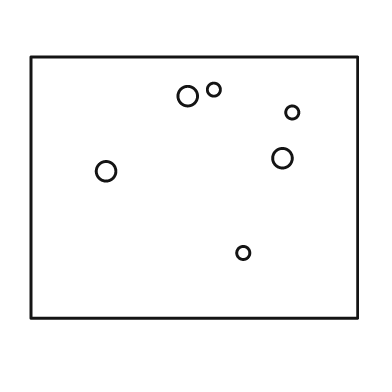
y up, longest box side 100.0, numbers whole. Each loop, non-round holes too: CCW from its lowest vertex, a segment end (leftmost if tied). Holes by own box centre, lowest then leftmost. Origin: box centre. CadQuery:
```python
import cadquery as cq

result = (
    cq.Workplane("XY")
    .moveTo(-50.0, -40.0)
    .lineTo(50.0, -40.0)
    .lineTo(50.0, 40.0)
    .lineTo(-50.0, 40.0)
    .close()
    .moveTo(15.0, -20.0)
    .circle(2.0)
    .moveTo(-27.0, 5.0)
    .circle(3.0)
    .moveTo(27.0, 9.0)
    .circle(3.0)
    .moveTo(30.0, 23.0)
    .circle(2.0)
    .moveTo(-2.0, 28.0)
    .circle(3.0)
    .moveTo(6.0, 30.0)
    .circle(2.0)
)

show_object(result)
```